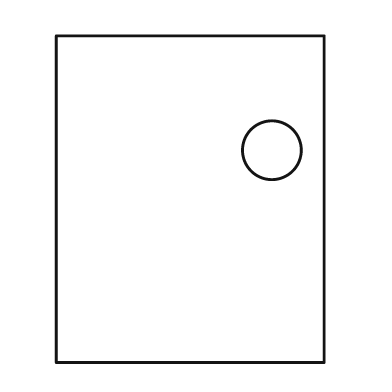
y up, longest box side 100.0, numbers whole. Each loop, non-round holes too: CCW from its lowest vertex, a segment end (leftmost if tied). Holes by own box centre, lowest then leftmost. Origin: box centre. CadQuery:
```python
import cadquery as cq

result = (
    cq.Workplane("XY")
    .moveTo(-41.0, -50.0)
    .lineTo(41.0, -50.0)
    .lineTo(41.0, 50.0)
    .lineTo(-41.0, 50.0)
    .close()
    .moveTo(25.0, 15.0)
    .circle(9.0)
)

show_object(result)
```